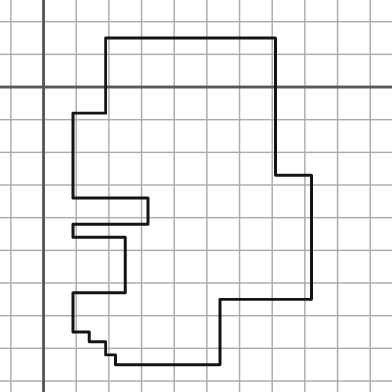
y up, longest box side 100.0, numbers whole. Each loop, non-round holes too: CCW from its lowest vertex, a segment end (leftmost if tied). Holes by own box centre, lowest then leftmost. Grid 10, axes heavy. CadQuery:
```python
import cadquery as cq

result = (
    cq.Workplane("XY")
    .moveTo(22.0, -85.0)
    .lineTo(54.0, -85.0)
    .lineTo(54.0, -65.0)
    .lineTo(82.0, -65.0)
    .lineTo(82.0, -27.0)
    .lineTo(71.0, -27.0)
    .lineTo(71.0, 15.0)
    .lineTo(19.0, 15.0)
    .lineTo(19.0, -8.0)
    .lineTo(9.0, -8.0)
    .lineTo(9.0, -34.0)
    .lineTo(32.0, -34.0)
    .lineTo(32.0, -42.0)
    .lineTo(9.0, -42.0)
    .lineTo(9.0, -46.0)
    .lineTo(25.0, -46.0)
    .lineTo(25.0, -63.0)
    .lineTo(9.0, -63.0)
    .lineTo(9.0, -75.0)
    .lineTo(14.0, -75.0)
    .lineTo(14.0, -78.0)
    .lineTo(19.0, -78.0)
    .lineTo(19.0, -82.0)
    .lineTo(22.0, -82.0)
    .close()
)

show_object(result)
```